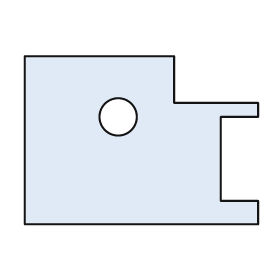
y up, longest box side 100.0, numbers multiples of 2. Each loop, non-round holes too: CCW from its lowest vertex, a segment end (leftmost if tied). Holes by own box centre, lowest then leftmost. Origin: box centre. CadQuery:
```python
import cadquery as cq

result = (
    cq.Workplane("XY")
    .moveTo(-50.0, -36.0)
    .lineTo(50.0, -36.0)
    .lineTo(50.0, -26.0)
    .lineTo(34.0, -26.0)
    .lineTo(34.0, 10.0)
    .lineTo(50.0, 10.0)
    .lineTo(50.0, 16.0)
    .lineTo(14.0, 16.0)
    .lineTo(14.0, 36.0)
    .lineTo(-50.0, 36.0)
    .close()
    .moveTo(-10.0, 10.0)
    .circle(8.0)
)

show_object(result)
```